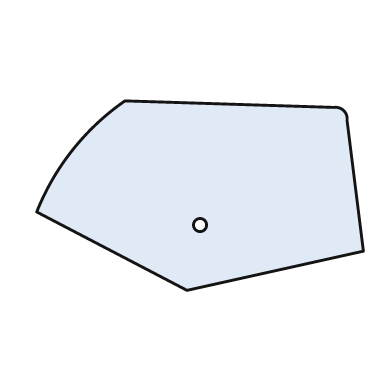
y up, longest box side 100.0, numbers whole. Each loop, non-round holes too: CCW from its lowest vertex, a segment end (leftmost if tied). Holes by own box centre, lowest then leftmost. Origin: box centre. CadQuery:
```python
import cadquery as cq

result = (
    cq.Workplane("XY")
    .moveTo(-4.0, -29.0)
    .lineTo(50.0, -17.0)
    .lineTo(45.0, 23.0)
    .threePointArc((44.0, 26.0), (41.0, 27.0))
    .lineTo(-23.0, 29.0)
    .threePointArc((-39.0, 14.0), (-50.0, -5.0))
    .close()
    .moveTo(0.0, -9.0)
    .circle(2.0)
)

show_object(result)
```